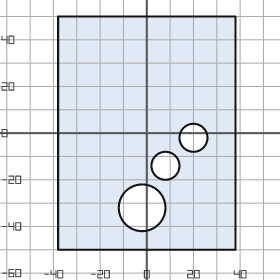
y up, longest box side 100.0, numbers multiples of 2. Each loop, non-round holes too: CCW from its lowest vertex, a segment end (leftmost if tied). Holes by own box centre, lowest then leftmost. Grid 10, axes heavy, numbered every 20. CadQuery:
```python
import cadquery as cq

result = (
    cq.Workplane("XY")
    .moveTo(-38.0, -50.0)
    .lineTo(38.0, -50.0)
    .lineTo(38.0, 50.0)
    .lineTo(-38.0, 50.0)
    .close()
    .moveTo(-2.0, -32.0)
    .circle(10.0)
    .moveTo(8.0, -14.0)
    .circle(6.0)
    .moveTo(20.0, -2.0)
    .circle(6.0)
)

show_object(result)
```